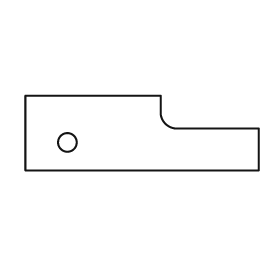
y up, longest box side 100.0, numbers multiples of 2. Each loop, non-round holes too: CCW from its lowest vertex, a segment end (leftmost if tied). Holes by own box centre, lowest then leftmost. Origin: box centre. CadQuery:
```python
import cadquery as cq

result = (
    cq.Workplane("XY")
    .moveTo(-50.0, -16.0)
    .lineTo(50.0, -16.0)
    .lineTo(50.0, 2.0)
    .lineTo(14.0, 2.0)
    .threePointArc((10.0, 4.0), (8.0, 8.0))
    .lineTo(8.0, 16.0)
    .lineTo(-50.0, 16.0)
    .close()
    .moveTo(-32.0, -4.0)
    .circle(4.0)
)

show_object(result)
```